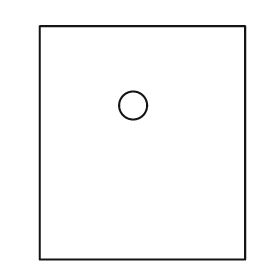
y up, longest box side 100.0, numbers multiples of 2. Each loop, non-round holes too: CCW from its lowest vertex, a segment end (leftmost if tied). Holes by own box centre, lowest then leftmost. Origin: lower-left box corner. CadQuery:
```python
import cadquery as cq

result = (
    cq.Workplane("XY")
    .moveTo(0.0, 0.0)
    .lineTo(88.0, 0.0)
    .lineTo(88.0, 100.0)
    .lineTo(0.0, 100.0)
    .close()
    .moveTo(40.0, 66.0)
    .circle(6.0)
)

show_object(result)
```